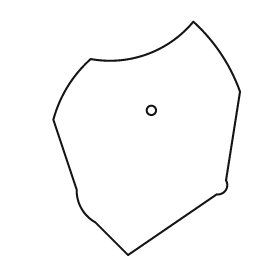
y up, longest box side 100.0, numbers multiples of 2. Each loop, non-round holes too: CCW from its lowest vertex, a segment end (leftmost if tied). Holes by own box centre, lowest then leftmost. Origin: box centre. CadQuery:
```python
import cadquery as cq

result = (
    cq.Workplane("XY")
    .moveTo(-8.0, -50.0)
    .lineTo(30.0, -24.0)
    .threePointArc((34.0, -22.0), (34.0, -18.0))
    .lineTo(40.0, 20.0)
    .threePointArc((32.0, 36.0), (20.0, 50.0))
    .threePointArc((0.0, 36.0), (-24.0, 34.0))
    .threePointArc((-34.0, 22.0), (-40.0, 8.0))
    .lineTo(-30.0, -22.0)
    .threePointArc((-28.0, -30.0), (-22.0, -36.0))
    .close()
    .moveTo(2.0, 12.0)
    .circle(2.0)
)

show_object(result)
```